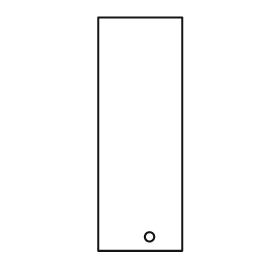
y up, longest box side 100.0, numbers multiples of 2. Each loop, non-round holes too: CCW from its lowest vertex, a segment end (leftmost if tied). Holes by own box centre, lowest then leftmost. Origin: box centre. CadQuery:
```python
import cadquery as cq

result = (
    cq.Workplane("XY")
    .moveTo(-18.0, -50.0)
    .lineTo(18.0, -50.0)
    .lineTo(18.0, 50.0)
    .lineTo(-18.0, 50.0)
    .close()
    .moveTo(4.0, -44.0)
    .circle(2.0)
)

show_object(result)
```